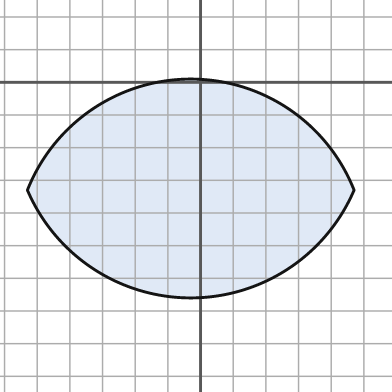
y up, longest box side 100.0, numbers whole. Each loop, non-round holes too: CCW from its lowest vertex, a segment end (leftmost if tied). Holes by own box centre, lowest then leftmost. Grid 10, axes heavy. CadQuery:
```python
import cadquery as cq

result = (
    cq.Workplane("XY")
    .moveTo(-53.0, -33.0)
    .threePointArc((-3.0, -66.0), (47.0, -33.0))
    .threePointArc((-3.0, 1.0), (-53.0, -33.0))
    .close()
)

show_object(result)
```